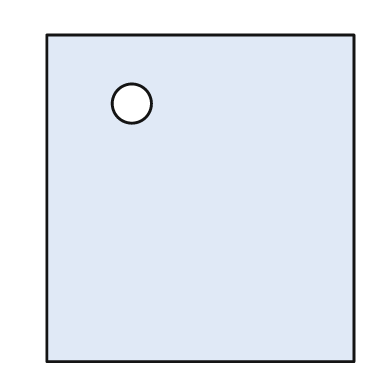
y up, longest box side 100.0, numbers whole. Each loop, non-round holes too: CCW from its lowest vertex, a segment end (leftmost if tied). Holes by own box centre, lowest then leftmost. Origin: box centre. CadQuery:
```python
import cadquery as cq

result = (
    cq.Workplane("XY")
    .moveTo(-47.0, -50.0)
    .lineTo(47.0, -50.0)
    .lineTo(47.0, 50.0)
    .lineTo(-47.0, 50.0)
    .close()
    .moveTo(-21.0, 29.0)
    .circle(6.0)
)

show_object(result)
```